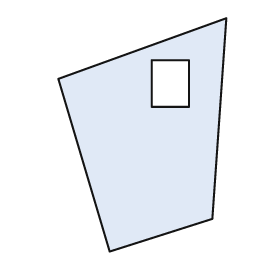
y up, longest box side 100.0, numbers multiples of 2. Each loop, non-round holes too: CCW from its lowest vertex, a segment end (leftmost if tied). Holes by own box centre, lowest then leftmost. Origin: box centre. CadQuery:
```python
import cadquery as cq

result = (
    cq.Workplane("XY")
    .moveTo(-14.0, -50.0)
    .lineTo(30.0, -36.0)
    .lineTo(36.0, 50.0)
    .lineTo(-36.0, 24.0)
    .close()
    .moveTo(4.0, 12.0)
    .lineTo(20.0, 12.0)
    .lineTo(20.0, 32.0)
    .lineTo(4.0, 32.0)
    .close()
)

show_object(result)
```